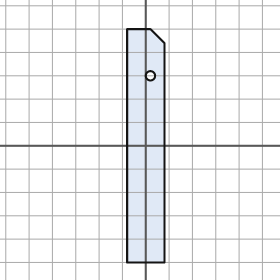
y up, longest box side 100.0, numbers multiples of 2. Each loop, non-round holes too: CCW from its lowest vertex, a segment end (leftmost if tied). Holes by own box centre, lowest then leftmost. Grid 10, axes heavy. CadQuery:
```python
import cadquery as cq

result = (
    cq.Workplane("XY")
    .moveTo(-8.0, -50.0)
    .lineTo(8.0, -50.0)
    .lineTo(8.0, 44.0)
    .lineTo(2.0, 50.0)
    .lineTo(-8.0, 50.0)
    .close()
    .moveTo(2.0, 30.0)
    .circle(2.0)
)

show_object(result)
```